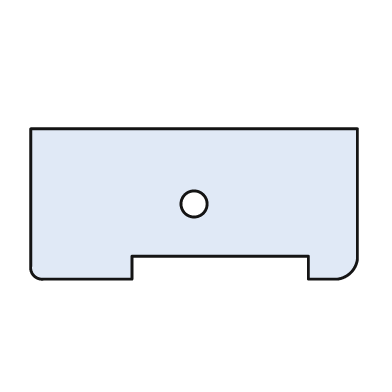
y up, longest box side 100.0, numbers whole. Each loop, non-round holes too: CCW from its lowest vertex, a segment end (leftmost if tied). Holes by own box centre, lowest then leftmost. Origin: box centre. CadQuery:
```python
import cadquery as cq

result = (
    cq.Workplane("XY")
    .moveTo(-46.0, -23.0)
    .lineTo(-19.0, -23.0)
    .lineTo(-19.0, -16.0)
    .lineTo(35.0, -16.0)
    .lineTo(35.0, -23.0)
    .lineTo(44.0, -23.0)
    .threePointArc((48.0, -21.0), (50.0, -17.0))
    .lineTo(50.0, 23.0)
    .lineTo(-50.0, 23.0)
    .lineTo(-50.0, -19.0)
    .threePointArc((-49.0, -22.0), (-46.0, -23.0))
    .close()
    .moveTo(0.0, 0.0)
    .circle(4.0)
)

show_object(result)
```